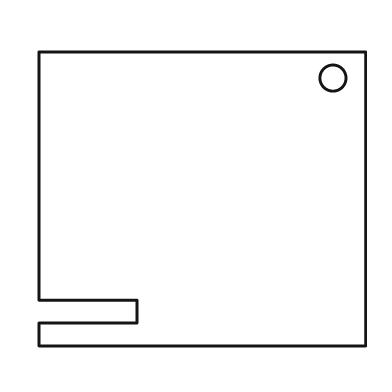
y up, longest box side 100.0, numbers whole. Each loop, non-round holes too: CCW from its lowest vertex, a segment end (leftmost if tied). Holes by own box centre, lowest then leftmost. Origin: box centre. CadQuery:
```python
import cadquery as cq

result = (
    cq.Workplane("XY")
    .moveTo(-50.0, -45.0)
    .lineTo(50.0, -45.0)
    .lineTo(50.0, 45.0)
    .lineTo(-50.0, 45.0)
    .lineTo(-50.0, -31.0)
    .lineTo(-20.0, -31.0)
    .lineTo(-20.0, -38.0)
    .lineTo(-50.0, -38.0)
    .close()
    .moveTo(40.0, 37.0)
    .circle(4.0)
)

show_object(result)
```